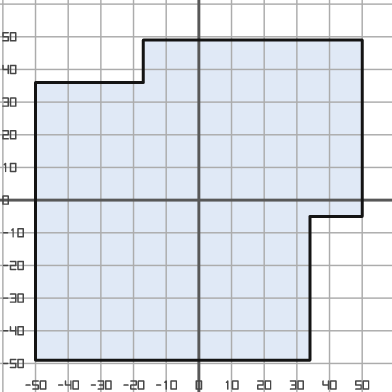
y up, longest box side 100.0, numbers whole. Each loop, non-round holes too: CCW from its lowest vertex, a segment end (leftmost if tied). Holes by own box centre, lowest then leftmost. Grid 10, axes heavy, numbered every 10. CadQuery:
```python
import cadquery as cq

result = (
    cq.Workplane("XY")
    .moveTo(-50.0, -49.0)
    .lineTo(34.0, -49.0)
    .lineTo(34.0, -5.0)
    .lineTo(50.0, -5.0)
    .lineTo(50.0, 49.0)
    .lineTo(-17.0, 49.0)
    .lineTo(-17.0, 36.0)
    .lineTo(-50.0, 36.0)
    .close()
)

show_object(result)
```